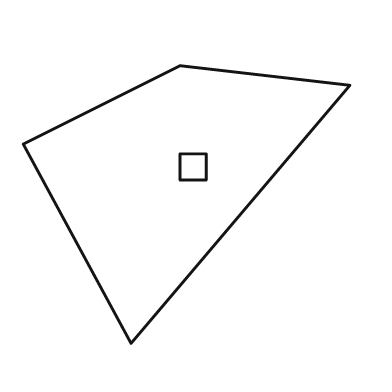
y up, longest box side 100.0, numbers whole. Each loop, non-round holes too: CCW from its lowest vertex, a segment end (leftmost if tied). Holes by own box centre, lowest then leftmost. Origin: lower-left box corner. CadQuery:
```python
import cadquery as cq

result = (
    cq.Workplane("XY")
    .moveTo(33.0, 0.0)
    .lineTo(100.0, 79.0)
    .lineTo(48.0, 85.0)
    .lineTo(0.0, 61.0)
    .close()
    .moveTo(48.0, 50.0)
    .lineTo(56.0, 50.0)
    .lineTo(56.0, 58.0)
    .lineTo(48.0, 58.0)
    .close()
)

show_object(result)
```